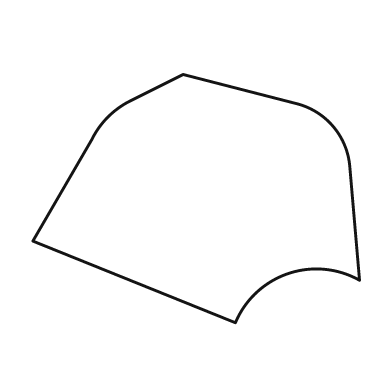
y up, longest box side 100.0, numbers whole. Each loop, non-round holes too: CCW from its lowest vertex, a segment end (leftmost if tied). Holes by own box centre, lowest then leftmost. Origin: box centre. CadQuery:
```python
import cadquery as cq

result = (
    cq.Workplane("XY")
    .moveTo(12.0, -38.0)
    .threePointArc((28.0, -23.0), (50.0, -25.0))
    .lineTo(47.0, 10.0)
    .threePointArc((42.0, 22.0), (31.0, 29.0))
    .lineTo(-4.0, 38.0)
    .lineTo(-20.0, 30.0)
    .threePointArc((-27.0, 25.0), (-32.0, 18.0))
    .lineTo(-50.0, -13.0)
    .close()
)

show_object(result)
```